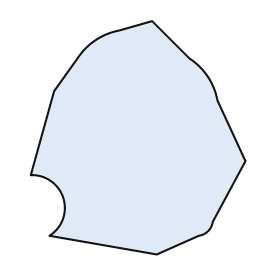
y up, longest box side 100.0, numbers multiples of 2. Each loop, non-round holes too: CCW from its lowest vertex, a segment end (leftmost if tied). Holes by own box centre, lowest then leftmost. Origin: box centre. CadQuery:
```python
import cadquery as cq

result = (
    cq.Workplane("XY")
    .moveTo(8.0, -50.0)
    .lineTo(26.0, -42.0)
    .threePointArc((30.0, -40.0), (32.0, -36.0))
    .lineTo(46.0, -10.0)
    .lineTo(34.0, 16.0)
    .threePointArc((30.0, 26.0), (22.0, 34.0))
    .lineTo(6.0, 50.0)
    .lineTo(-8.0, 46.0)
    .threePointArc((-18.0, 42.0), (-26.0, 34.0))
    .lineTo(-36.0, 20.0)
    .lineTo(-46.0, -16.0)
    .threePointArc((-32.0, -26.0), (-38.0, -42.0))
    .close()
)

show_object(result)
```